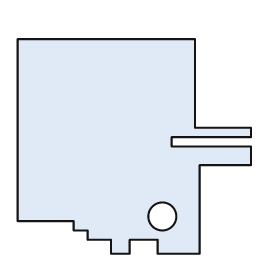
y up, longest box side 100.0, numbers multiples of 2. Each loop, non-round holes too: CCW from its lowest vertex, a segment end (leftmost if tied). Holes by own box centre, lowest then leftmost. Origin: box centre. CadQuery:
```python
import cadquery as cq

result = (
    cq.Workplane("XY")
    .moveTo(-10.0, -46.0)
    .lineTo(-2.0, -46.0)
    .lineTo(-2.0, -40.0)
    .lineTo(10.0, -40.0)
    .lineTo(10.0, -46.0)
    .lineTo(28.0, -46.0)
    .lineTo(28.0, -8.0)
    .lineTo(50.0, -8.0)
    .lineTo(50.0, 0.0)
    .lineTo(16.0, 0.0)
    .lineTo(16.0, 4.0)
    .lineTo(50.0, 4.0)
    .lineTo(50.0, 8.0)
    .lineTo(26.0, 8.0)
    .lineTo(26.0, 46.0)
    .lineTo(-50.0, 46.0)
    .lineTo(-50.0, -32.0)
    .lineTo(-26.0, -32.0)
    .lineTo(-26.0, -36.0)
    .lineTo(-20.0, -36.0)
    .lineTo(-20.0, -40.0)
    .lineTo(-10.0, -40.0)
    .close()
    .moveTo(12.0, -30.0)
    .circle(6.0)
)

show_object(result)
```